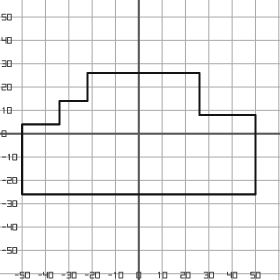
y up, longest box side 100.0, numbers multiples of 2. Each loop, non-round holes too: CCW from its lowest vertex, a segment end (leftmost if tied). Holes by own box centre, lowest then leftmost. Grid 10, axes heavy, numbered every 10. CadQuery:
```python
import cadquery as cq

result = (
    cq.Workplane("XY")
    .moveTo(-50.0, -26.0)
    .lineTo(50.0, -26.0)
    .lineTo(50.0, 8.0)
    .lineTo(26.0, 8.0)
    .lineTo(26.0, 26.0)
    .lineTo(-22.0, 26.0)
    .lineTo(-22.0, 14.0)
    .lineTo(-34.0, 14.0)
    .lineTo(-34.0, 4.0)
    .lineTo(-50.0, 4.0)
    .close()
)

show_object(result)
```